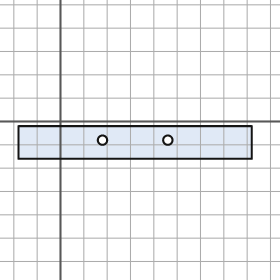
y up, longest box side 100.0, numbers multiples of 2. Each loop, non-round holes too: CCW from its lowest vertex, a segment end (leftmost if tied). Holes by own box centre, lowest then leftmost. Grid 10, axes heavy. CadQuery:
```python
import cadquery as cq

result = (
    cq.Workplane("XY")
    .moveTo(-18.0, -16.0)
    .lineTo(82.0, -16.0)
    .lineTo(82.0, -2.0)
    .lineTo(-18.0, -2.0)
    .close()
    .moveTo(18.0, -8.0)
    .circle(2.0)
    .moveTo(46.0, -8.0)
    .circle(2.0)
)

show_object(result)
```